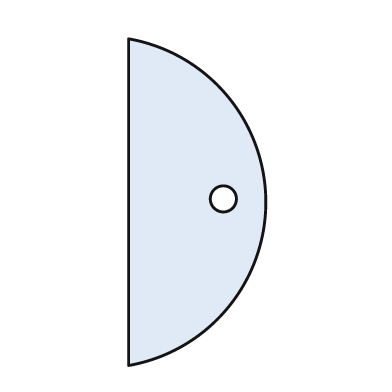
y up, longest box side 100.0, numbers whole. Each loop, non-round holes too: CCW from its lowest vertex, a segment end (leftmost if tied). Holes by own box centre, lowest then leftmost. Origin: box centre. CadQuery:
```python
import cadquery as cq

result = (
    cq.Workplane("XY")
    .moveTo(-21.0, -50.0)
    .threePointArc((21.0, 0.0), (-21.0, 50.0))
    .close()
    .moveTo(8.0, 1.0)
    .circle(4.0)
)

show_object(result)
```